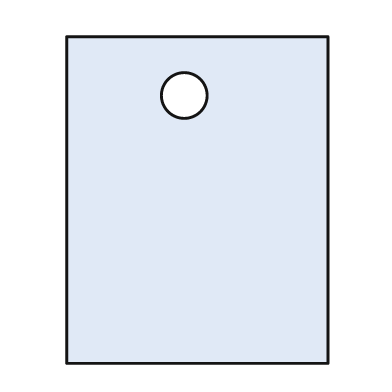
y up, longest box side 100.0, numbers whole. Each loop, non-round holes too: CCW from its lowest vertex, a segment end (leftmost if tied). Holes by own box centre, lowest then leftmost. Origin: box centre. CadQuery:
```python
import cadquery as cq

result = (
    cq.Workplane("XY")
    .moveTo(-40.0, -50.0)
    .lineTo(40.0, -50.0)
    .lineTo(40.0, 50.0)
    .lineTo(-40.0, 50.0)
    .close()
    .moveTo(-4.0, 32.0)
    .circle(7.0)
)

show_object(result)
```